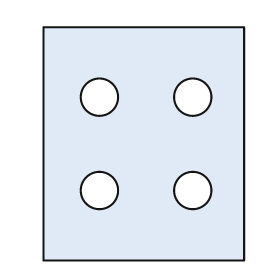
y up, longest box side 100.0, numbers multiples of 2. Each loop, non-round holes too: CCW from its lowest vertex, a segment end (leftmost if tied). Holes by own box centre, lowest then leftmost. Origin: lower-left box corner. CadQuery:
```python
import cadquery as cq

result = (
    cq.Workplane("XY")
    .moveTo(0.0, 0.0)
    .lineTo(86.0, 0.0)
    .lineTo(86.0, 100.0)
    .lineTo(0.0, 100.0)
    .close()
    .moveTo(24.0, 30.0)
    .circle(8.0)
    .moveTo(64.0, 30.0)
    .circle(8.0)
    .moveTo(24.0, 70.0)
    .circle(8.0)
    .moveTo(64.0, 70.0)
    .circle(8.0)
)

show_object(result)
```